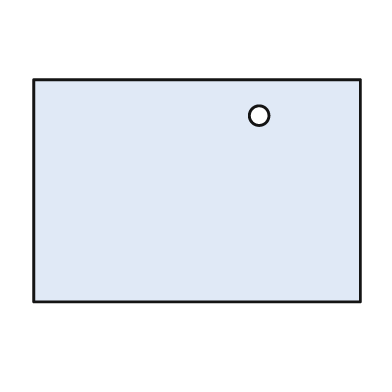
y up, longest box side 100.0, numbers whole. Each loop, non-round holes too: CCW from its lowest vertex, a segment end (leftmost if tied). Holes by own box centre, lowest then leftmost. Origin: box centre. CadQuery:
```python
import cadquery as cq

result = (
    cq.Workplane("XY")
    .moveTo(-50.0, -34.0)
    .lineTo(50.0, -34.0)
    .lineTo(50.0, 34.0)
    .lineTo(-50.0, 34.0)
    .close()
    .moveTo(19.0, 23.0)
    .circle(3.0)
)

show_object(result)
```